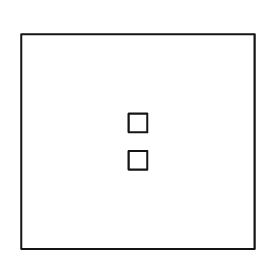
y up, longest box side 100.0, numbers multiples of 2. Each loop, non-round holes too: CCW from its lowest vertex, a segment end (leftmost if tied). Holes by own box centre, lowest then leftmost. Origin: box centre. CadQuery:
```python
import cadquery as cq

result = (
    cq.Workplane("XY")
    .moveTo(-50.0, -46.0)
    .lineTo(50.0, -46.0)
    .lineTo(50.0, 46.0)
    .lineTo(-50.0, 46.0)
    .close()
    .moveTo(-4.0, -12.0)
    .lineTo(4.0, -12.0)
    .lineTo(4.0, -4.0)
    .lineTo(-4.0, -4.0)
    .close()
    .moveTo(-4.0, 4.0)
    .lineTo(4.0, 4.0)
    .lineTo(4.0, 12.0)
    .lineTo(-4.0, 12.0)
    .close()
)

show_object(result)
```